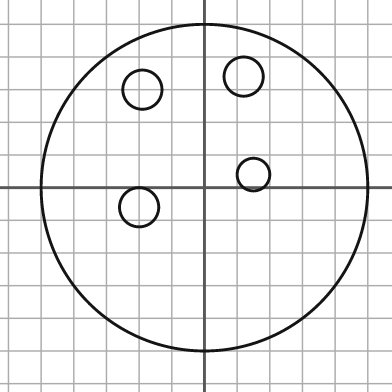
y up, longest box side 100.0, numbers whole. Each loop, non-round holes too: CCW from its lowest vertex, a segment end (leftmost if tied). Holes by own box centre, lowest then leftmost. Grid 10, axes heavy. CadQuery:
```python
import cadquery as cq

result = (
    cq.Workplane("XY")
    .moveTo(0.0, 0.0)
    .circle(50.0)
    .moveTo(-20.0, -6.0)
    .circle(6.0)
    .moveTo(15.0, 4.0)
    .circle(5.0)
    .moveTo(-19.0, 30.0)
    .circle(6.0)
    .moveTo(12.0, 34.0)
    .circle(6.0)
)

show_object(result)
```